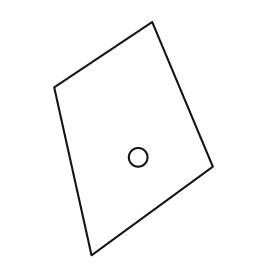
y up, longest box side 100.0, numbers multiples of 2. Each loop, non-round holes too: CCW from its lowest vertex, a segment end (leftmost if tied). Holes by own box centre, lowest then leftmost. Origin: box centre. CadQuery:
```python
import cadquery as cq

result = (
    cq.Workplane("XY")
    .moveTo(-18.0, -50.0)
    .lineTo(34.0, -12.0)
    .lineTo(8.0, 50.0)
    .lineTo(-34.0, 22.0)
    .close()
    .moveTo(2.0, -8.0)
    .circle(4.0)
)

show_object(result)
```